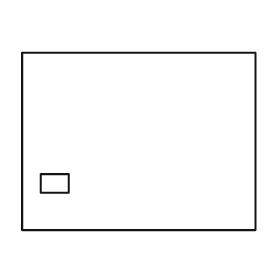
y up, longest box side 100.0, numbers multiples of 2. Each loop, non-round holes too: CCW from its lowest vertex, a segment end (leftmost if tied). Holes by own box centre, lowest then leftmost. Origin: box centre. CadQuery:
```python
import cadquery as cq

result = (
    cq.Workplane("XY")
    .moveTo(-50.0, -38.0)
    .lineTo(50.0, -38.0)
    .lineTo(50.0, 38.0)
    .lineTo(-50.0, 38.0)
    .close()
    .moveTo(-42.0, -22.0)
    .lineTo(-30.0, -22.0)
    .lineTo(-30.0, -14.0)
    .lineTo(-42.0, -14.0)
    .close()
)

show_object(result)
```